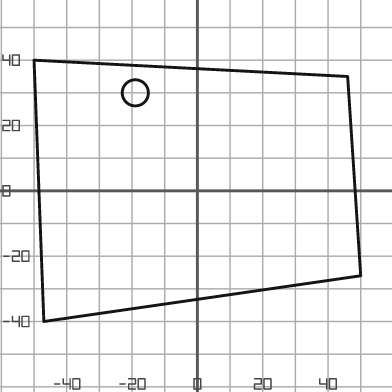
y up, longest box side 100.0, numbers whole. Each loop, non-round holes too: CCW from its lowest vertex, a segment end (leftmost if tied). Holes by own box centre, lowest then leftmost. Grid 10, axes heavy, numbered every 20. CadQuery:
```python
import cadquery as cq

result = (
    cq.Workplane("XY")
    .moveTo(-47.0, -40.0)
    .lineTo(50.0, -26.0)
    .lineTo(46.0, 35.0)
    .lineTo(-50.0, 40.0)
    .close()
    .moveTo(-19.0, 30.0)
    .circle(4.0)
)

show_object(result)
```